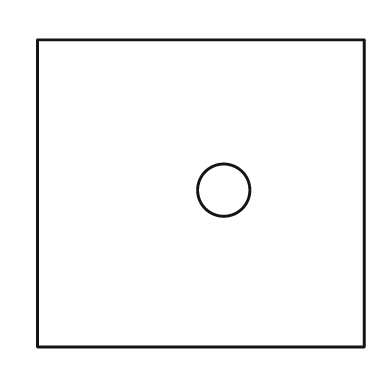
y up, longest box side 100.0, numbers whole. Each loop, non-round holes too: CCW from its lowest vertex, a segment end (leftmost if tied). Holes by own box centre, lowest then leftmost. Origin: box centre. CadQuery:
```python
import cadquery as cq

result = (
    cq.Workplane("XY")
    .moveTo(-50.0, -47.0)
    .lineTo(50.0, -47.0)
    .lineTo(50.0, 47.0)
    .lineTo(-50.0, 47.0)
    .close()
    .moveTo(7.0, 1.0)
    .circle(8.0)
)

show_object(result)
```